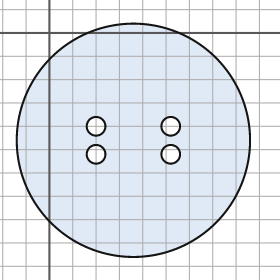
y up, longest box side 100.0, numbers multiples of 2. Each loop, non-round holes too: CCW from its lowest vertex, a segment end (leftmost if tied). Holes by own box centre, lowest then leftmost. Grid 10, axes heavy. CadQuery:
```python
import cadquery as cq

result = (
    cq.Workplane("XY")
    .moveTo(36.0, -46.0)
    .circle(50.0)
    .moveTo(20.0, -52.0)
    .circle(4.0)
    .moveTo(52.0, -52.0)
    .circle(4.0)
    .moveTo(20.0, -40.0)
    .circle(4.0)
    .moveTo(52.0, -40.0)
    .circle(4.0)
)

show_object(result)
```